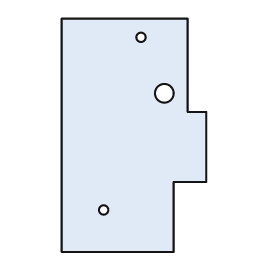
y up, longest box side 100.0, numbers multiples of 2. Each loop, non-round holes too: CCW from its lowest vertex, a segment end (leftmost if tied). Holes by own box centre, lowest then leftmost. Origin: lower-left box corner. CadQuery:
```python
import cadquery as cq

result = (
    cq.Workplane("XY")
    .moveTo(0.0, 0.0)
    .lineTo(48.0, 0.0)
    .lineTo(48.0, 30.0)
    .lineTo(62.0, 30.0)
    .lineTo(62.0, 60.0)
    .lineTo(54.0, 60.0)
    .lineTo(54.0, 100.0)
    .lineTo(0.0, 100.0)
    .close()
    .moveTo(18.0, 18.0)
    .circle(2.0)
    .moveTo(44.0, 68.0)
    .circle(4.0)
    .moveTo(34.0, 92.0)
    .circle(2.0)
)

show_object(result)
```